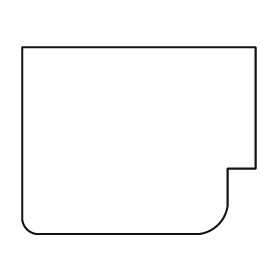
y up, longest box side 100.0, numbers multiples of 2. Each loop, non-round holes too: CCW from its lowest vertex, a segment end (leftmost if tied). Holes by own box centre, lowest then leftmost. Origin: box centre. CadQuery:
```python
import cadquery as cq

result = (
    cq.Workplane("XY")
    .moveTo(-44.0, -40.0)
    .lineTo(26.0, -40.0)
    .threePointArc((34.0, -36.0), (38.0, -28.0))
    .lineTo(38.0, -12.0)
    .lineTo(50.0, -12.0)
    .lineTo(50.0, 40.0)
    .lineTo(-50.0, 40.0)
    .lineTo(-50.0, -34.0)
    .threePointArc((-48.0, -38.0), (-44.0, -40.0))
    .close()
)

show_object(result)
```